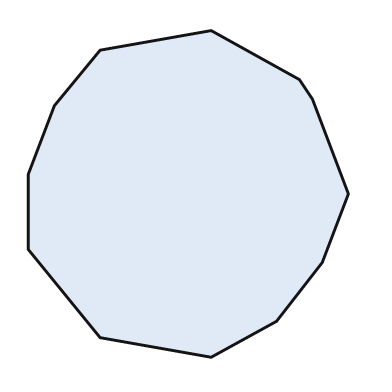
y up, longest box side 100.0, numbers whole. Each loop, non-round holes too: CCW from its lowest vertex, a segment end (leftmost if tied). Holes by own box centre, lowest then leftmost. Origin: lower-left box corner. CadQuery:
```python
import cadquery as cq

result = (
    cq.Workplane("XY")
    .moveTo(56.0, 0.0)
    .lineTo(76.0, 11.0)
    .lineTo(90.0, 29.0)
    .lineTo(98.0, 50.0)
    .lineTo(87.0, 79.0)
    .lineTo(83.0, 85.0)
    .lineTo(56.0, 100.0)
    .lineTo(22.0, 94.0)
    .lineTo(8.0, 77.0)
    .lineTo(0.0, 56.0)
    .lineTo(0.0, 33.0)
    .lineTo(22.0, 6.0)
    .close()
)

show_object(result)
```